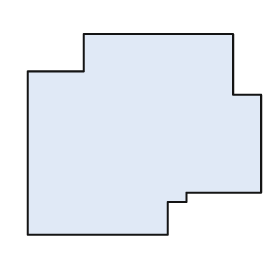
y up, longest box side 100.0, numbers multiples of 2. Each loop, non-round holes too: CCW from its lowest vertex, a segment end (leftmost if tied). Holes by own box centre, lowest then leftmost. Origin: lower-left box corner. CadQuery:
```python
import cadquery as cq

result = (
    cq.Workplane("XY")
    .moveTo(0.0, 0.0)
    .lineTo(60.0, 0.0)
    .lineTo(60.0, 14.0)
    .lineTo(68.0, 14.0)
    .lineTo(68.0, 18.0)
    .lineTo(100.0, 18.0)
    .lineTo(100.0, 60.0)
    .lineTo(88.0, 60.0)
    .lineTo(88.0, 86.0)
    .lineTo(24.0, 86.0)
    .lineTo(24.0, 70.0)
    .lineTo(0.0, 70.0)
    .close()
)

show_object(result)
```